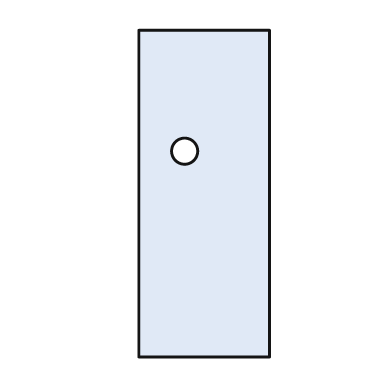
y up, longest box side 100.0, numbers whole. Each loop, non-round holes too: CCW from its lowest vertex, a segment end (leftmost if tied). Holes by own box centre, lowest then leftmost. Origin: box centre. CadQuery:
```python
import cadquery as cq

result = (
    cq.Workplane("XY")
    .moveTo(-20.0, -50.0)
    .lineTo(20.0, -50.0)
    .lineTo(20.0, 50.0)
    .lineTo(-20.0, 50.0)
    .close()
    .moveTo(-6.0, 13.0)
    .circle(4.0)
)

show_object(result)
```